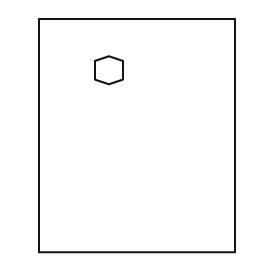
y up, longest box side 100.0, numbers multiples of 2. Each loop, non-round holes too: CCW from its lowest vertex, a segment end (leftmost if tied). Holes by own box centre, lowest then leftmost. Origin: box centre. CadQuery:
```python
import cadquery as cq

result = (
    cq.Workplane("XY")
    .moveTo(-42.0, -50.0)
    .lineTo(42.0, -50.0)
    .lineTo(42.0, 50.0)
    .lineTo(-42.0, 50.0)
    .close()
    .moveTo(-12.0, 22.0)
    .lineTo(-6.0, 24.0)
    .lineTo(-6.0, 32.0)
    .lineTo(-12.0, 34.0)
    .lineTo(-18.0, 32.0)
    .lineTo(-18.0, 24.0)
    .close()
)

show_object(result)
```